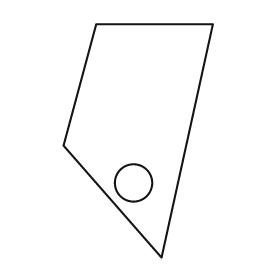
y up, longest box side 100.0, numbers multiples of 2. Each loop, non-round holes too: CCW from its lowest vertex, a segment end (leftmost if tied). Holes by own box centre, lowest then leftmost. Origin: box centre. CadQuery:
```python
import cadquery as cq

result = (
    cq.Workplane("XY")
    .moveTo(10.0, -50.0)
    .lineTo(32.0, 50.0)
    .lineTo(-18.0, 50.0)
    .lineTo(-32.0, -2.0)
    .close()
    .moveTo(-2.0, -18.0)
    .circle(8.0)
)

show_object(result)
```